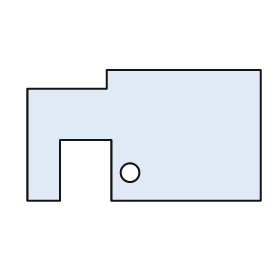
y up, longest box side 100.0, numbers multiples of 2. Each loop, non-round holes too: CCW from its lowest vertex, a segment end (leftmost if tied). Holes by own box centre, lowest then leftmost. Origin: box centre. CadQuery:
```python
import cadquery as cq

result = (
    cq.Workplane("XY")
    .moveTo(-50.0, -28.0)
    .lineTo(-36.0, -28.0)
    .lineTo(-36.0, -2.0)
    .lineTo(-14.0, -2.0)
    .lineTo(-14.0, -28.0)
    .lineTo(50.0, -28.0)
    .lineTo(50.0, 28.0)
    .lineTo(-16.0, 28.0)
    .lineTo(-16.0, 20.0)
    .lineTo(-50.0, 20.0)
    .close()
    .moveTo(-6.0, -16.0)
    .circle(4.0)
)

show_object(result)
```